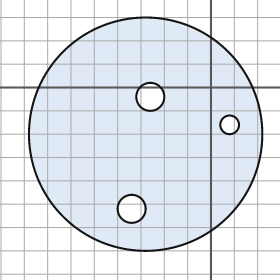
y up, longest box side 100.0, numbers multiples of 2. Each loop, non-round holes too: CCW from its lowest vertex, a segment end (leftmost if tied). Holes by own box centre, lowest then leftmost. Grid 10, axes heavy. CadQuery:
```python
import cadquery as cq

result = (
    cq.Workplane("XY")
    .moveTo(-28.0, -20.0)
    .circle(50.0)
    .moveTo(-34.0, -52.0)
    .circle(6.0)
    .moveTo(8.0, -16.0)
    .circle(4.0)
    .moveTo(-26.0, -4.0)
    .circle(6.0)
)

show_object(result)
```